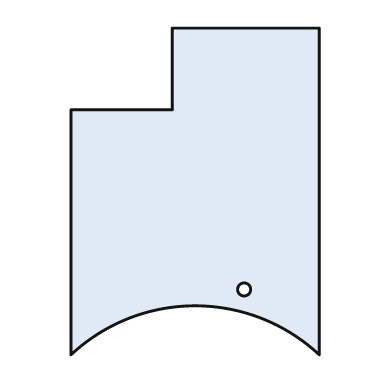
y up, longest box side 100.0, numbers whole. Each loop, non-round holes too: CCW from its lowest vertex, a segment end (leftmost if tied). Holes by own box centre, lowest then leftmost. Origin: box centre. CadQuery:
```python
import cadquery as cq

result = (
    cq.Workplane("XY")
    .moveTo(-38.0, -50.0)
    .threePointArc((0.0, -35.0), (38.0, -50.0))
    .lineTo(38.0, 50.0)
    .lineTo(-7.0, 50.0)
    .lineTo(-7.0, 25.0)
    .lineTo(-38.0, 25.0)
    .close()
    .moveTo(15.0, -30.0)
    .circle(2.0)
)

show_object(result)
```